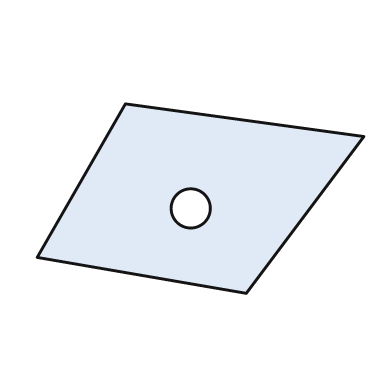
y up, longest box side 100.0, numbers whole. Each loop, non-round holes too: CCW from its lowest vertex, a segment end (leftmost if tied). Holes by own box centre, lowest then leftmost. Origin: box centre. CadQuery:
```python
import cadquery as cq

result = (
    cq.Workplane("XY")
    .moveTo(14.0, -29.0)
    .lineTo(50.0, 19.0)
    .lineTo(-23.0, 29.0)
    .lineTo(-50.0, -18.0)
    .close()
    .moveTo(-3.0, -3.0)
    .circle(6.0)
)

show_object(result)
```